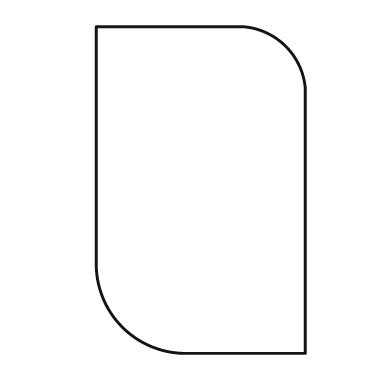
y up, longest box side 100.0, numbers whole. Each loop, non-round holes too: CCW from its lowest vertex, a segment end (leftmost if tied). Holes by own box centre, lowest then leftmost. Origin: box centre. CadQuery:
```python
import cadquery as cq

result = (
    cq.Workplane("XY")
    .moveTo(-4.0, -50.0)
    .lineTo(32.0, -50.0)
    .lineTo(32.0, 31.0)
    .threePointArc((26.0, 44.0), (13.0, 50.0))
    .lineTo(-32.0, 50.0)
    .lineTo(-32.0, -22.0)
    .threePointArc((-24.0, -42.0), (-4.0, -50.0))
    .close()
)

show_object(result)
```